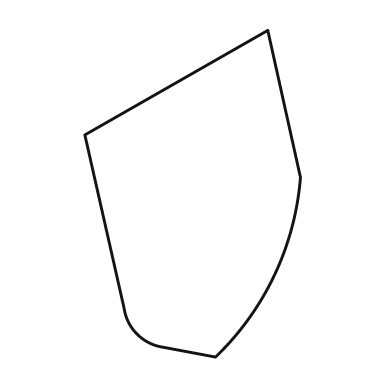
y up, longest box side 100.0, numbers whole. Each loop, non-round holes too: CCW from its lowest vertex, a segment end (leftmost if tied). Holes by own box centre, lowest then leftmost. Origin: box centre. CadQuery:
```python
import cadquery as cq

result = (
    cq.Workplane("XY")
    .moveTo(7.0, -50.0)
    .threePointArc((25.0, -25.0), (33.0, 5.0))
    .lineTo(23.0, 50.0)
    .lineTo(-33.0, 18.0)
    .lineTo(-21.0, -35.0)
    .threePointArc((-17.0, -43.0), (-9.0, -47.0))
    .close()
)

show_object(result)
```